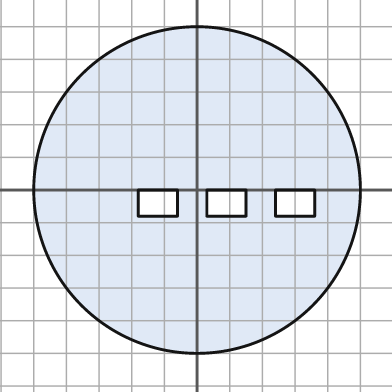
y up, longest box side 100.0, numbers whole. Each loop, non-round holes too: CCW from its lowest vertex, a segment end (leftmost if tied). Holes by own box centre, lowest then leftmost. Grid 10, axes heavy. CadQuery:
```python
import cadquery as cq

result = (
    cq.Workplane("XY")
    .moveTo(0.0, 0.0)
    .circle(50.0)
    .moveTo(-18.0, -8.0)
    .lineTo(-6.0, -8.0)
    .lineTo(-6.0, 0.0)
    .lineTo(-18.0, 0.0)
    .close()
    .moveTo(3.0, -8.0)
    .lineTo(15.0, -8.0)
    .lineTo(15.0, 0.0)
    .lineTo(3.0, 0.0)
    .close()
    .moveTo(24.0, -8.0)
    .lineTo(36.0, -8.0)
    .lineTo(36.0, 0.0)
    .lineTo(24.0, 0.0)
    .close()
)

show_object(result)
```